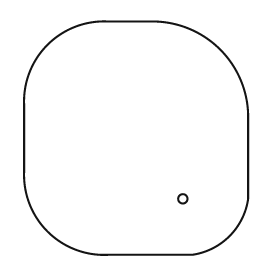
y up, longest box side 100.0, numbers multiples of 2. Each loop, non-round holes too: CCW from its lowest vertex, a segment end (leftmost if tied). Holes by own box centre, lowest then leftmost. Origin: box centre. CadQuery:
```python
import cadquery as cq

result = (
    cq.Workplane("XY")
    .moveTo(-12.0, -50.0)
    .lineTo(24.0, -50.0)
    .threePointArc((40.0, -42.0), (48.0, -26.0))
    .lineTo(48.0, 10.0)
    .threePointArc((36.0, 38.0), (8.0, 50.0))
    .lineTo(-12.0, 50.0)
    .threePointArc((-38.0, 40.0), (-48.0, 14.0))
    .lineTo(-48.0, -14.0)
    .threePointArc((-38.0, -40.0), (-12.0, -50.0))
    .close()
    .moveTo(20.0, -26.0)
    .circle(2.0)
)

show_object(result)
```